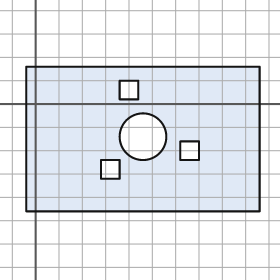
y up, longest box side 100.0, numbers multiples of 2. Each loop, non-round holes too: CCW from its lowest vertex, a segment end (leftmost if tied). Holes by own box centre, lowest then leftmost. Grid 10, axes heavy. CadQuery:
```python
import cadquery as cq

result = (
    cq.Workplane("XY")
    .moveTo(-4.0, -46.0)
    .lineTo(96.0, -46.0)
    .lineTo(96.0, 16.0)
    .lineTo(-4.0, 16.0)
    .close()
    .moveTo(28.0, -32.0)
    .lineTo(36.0, -32.0)
    .lineTo(36.0, -24.0)
    .lineTo(28.0, -24.0)
    .close()
    .moveTo(62.0, -24.0)
    .lineTo(70.0, -24.0)
    .lineTo(70.0, -16.0)
    .lineTo(62.0, -16.0)
    .close()
    .moveTo(46.0, -14.0)
    .circle(10.0)
    .moveTo(36.0, 2.0)
    .lineTo(44.0, 2.0)
    .lineTo(44.0, 10.0)
    .lineTo(36.0, 10.0)
    .close()
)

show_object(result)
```